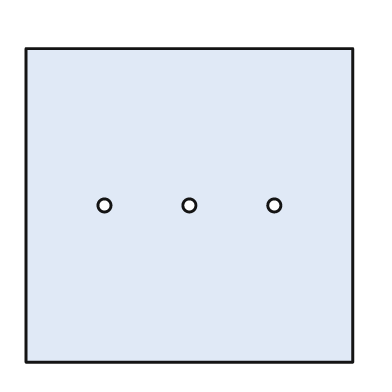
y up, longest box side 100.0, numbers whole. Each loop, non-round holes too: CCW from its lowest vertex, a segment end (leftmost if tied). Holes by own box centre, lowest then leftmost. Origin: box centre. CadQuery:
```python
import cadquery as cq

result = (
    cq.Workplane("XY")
    .moveTo(-50.0, -48.0)
    .lineTo(50.0, -48.0)
    .lineTo(50.0, 48.0)
    .lineTo(-50.0, 48.0)
    .close()
    .moveTo(-26.0, 0.0)
    .circle(2.0)
    .moveTo(0.0, 0.0)
    .circle(2.0)
    .moveTo(26.0, 0.0)
    .circle(2.0)
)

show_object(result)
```